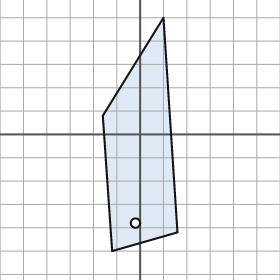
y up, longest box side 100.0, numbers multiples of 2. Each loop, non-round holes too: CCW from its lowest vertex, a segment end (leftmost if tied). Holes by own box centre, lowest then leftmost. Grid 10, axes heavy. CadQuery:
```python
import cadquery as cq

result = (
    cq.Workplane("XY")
    .moveTo(-12.0, -50.0)
    .lineTo(16.0, -42.0)
    .lineTo(10.0, 50.0)
    .lineTo(-16.0, 8.0)
    .close()
    .moveTo(-2.0, -38.0)
    .circle(2.0)
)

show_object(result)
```